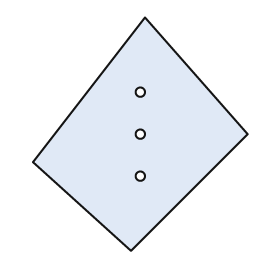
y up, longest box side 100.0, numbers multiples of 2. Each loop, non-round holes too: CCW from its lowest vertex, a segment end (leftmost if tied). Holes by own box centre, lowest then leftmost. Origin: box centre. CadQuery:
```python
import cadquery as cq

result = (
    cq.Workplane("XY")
    .moveTo(-4.0, -50.0)
    .lineTo(46.0, 0.0)
    .lineTo(2.0, 50.0)
    .lineTo(-46.0, -12.0)
    .close()
    .moveTo(0.0, -18.0)
    .circle(2.0)
    .moveTo(0.0, 0.0)
    .circle(2.0)
    .moveTo(0.0, 18.0)
    .circle(2.0)
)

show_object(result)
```